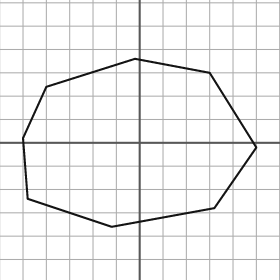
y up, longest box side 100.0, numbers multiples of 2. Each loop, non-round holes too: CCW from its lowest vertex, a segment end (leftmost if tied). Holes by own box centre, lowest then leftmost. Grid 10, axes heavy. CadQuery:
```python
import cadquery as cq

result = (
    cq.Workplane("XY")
    .moveTo(-12.0, -36.0)
    .lineTo(32.0, -28.0)
    .lineTo(50.0, -2.0)
    .lineTo(30.0, 30.0)
    .lineTo(-2.0, 36.0)
    .lineTo(-40.0, 24.0)
    .lineTo(-50.0, 2.0)
    .lineTo(-48.0, -24.0)
    .close()
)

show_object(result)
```